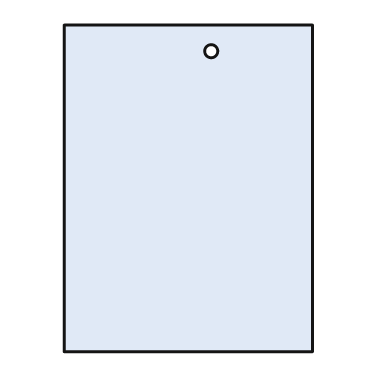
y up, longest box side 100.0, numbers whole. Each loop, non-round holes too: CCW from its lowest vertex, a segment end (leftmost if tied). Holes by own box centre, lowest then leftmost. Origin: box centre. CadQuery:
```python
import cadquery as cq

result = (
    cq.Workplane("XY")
    .moveTo(-38.0, -50.0)
    .lineTo(38.0, -50.0)
    .lineTo(38.0, 50.0)
    .lineTo(-38.0, 50.0)
    .close()
    .moveTo(7.0, 42.0)
    .circle(2.0)
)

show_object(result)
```